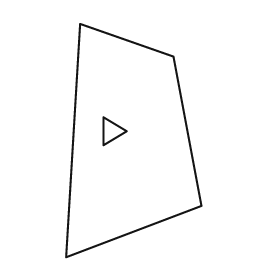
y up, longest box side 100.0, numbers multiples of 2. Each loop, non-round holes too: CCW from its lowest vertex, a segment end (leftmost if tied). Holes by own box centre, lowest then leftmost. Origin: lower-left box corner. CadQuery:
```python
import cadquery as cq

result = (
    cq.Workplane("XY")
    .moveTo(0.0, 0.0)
    .lineTo(58.0, 22.0)
    .lineTo(46.0, 86.0)
    .lineTo(6.0, 100.0)
    .close()
    .moveTo(16.0, 48.0)
    .lineTo(26.0, 54.0)
    .lineTo(16.0, 60.0)
    .close()
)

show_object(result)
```